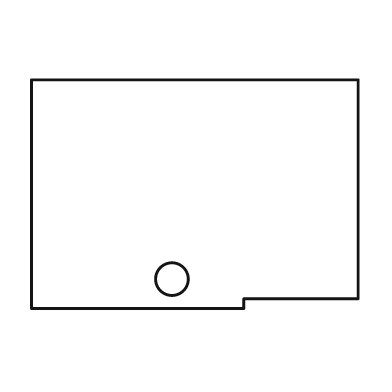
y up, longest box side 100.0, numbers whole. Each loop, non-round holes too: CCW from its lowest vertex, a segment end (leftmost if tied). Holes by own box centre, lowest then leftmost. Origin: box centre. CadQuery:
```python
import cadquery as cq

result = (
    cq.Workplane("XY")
    .moveTo(-50.0, -35.0)
    .lineTo(15.0, -35.0)
    .lineTo(15.0, -32.0)
    .lineTo(50.0, -32.0)
    .lineTo(50.0, 35.0)
    .lineTo(-50.0, 35.0)
    .close()
    .moveTo(-7.0, -26.0)
    .circle(5.0)
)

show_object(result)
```